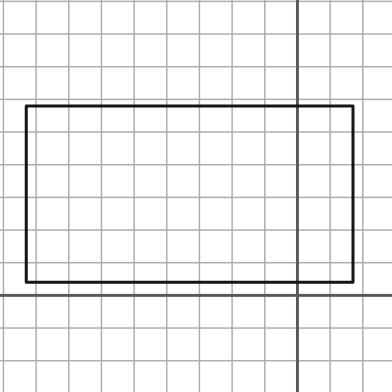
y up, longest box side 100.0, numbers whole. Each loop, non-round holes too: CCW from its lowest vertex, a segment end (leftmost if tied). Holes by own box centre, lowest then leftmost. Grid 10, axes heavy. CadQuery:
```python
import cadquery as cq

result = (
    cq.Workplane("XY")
    .moveTo(-83.0, 4.0)
    .lineTo(17.0, 4.0)
    .lineTo(17.0, 58.0)
    .lineTo(-83.0, 58.0)
    .close()
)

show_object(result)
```